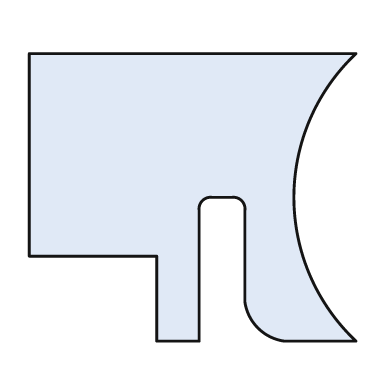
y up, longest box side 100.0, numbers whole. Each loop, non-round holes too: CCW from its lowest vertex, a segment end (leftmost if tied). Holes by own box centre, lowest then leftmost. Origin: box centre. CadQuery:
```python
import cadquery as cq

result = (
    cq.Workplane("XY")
    .moveTo(-11.0, -44.0)
    .lineTo(2.0, -44.0)
    .lineTo(2.0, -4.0)
    .threePointArc((3.0, -1.0), (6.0, 0.0))
    .lineTo(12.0, 0.0)
    .threePointArc((15.0, -1.0), (16.0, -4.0))
    .lineTo(16.0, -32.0)
    .threePointArc((20.0, -40.0), (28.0, -44.0))
    .lineTo(50.0, -44.0)
    .threePointArc((31.0, 0.0), (50.0, 44.0))
    .lineTo(-50.0, 44.0)
    .lineTo(-50.0, -18.0)
    .lineTo(-11.0, -18.0)
    .close()
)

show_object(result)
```